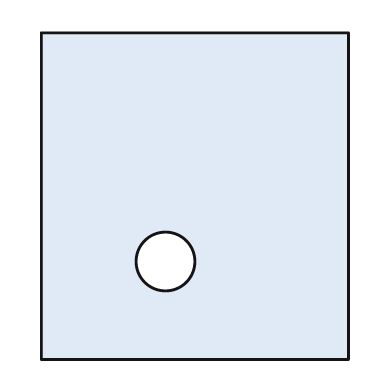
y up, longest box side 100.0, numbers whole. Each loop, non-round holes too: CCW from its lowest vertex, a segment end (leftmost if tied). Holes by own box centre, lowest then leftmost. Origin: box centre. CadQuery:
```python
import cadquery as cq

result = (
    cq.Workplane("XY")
    .moveTo(-47.0, -50.0)
    .lineTo(47.0, -50.0)
    .lineTo(47.0, 50.0)
    .lineTo(-47.0, 50.0)
    .close()
    .moveTo(-9.0, -20.0)
    .circle(9.0)
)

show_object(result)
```